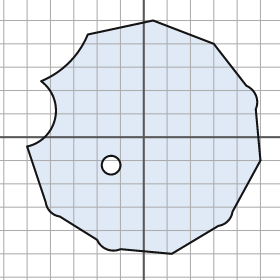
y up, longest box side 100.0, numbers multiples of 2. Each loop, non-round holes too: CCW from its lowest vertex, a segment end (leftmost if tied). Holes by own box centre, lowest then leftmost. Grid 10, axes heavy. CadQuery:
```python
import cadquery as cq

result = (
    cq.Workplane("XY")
    .moveTo(12.0, -50.0)
    .lineTo(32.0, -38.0)
    .threePointArc((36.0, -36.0), (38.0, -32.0))
    .lineTo(50.0, -10.0)
    .lineTo(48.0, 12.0)
    .threePointArc((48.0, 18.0), (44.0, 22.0))
    .lineTo(30.0, 40.0)
    .lineTo(4.0, 50.0)
    .lineTo(-24.0, 44.0)
    .threePointArc((-32.0, 32.0), (-44.0, 24.0))
    .threePointArc((-38.0, 8.0), (-50.0, -4.0))
    .lineTo(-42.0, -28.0)
    .threePointArc((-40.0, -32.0), (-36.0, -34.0))
    .lineTo(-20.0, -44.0)
    .threePointArc((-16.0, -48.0), (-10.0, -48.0))
    .close()
    .moveTo(-14.0, -12.0)
    .circle(4.0)
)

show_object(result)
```